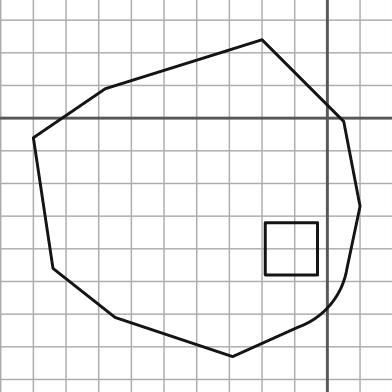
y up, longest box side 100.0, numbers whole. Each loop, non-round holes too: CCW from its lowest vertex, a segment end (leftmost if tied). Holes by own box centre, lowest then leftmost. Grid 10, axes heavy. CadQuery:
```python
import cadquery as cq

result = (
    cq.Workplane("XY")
    .moveTo(-29.0, -73.0)
    .lineTo(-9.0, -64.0)
    .threePointArc((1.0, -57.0), (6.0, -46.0))
    .lineTo(10.0, -27.0)
    .lineTo(5.0, -1.0)
    .lineTo(-20.0, 24.0)
    .lineTo(-68.0, 9.0)
    .lineTo(-90.0, -6.0)
    .lineTo(-84.0, -46.0)
    .lineTo(-65.0, -61.0)
    .close()
    .moveTo(-19.0, -48.0)
    .lineTo(-3.0, -48.0)
    .lineTo(-3.0, -32.0)
    .lineTo(-19.0, -32.0)
    .close()
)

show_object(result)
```